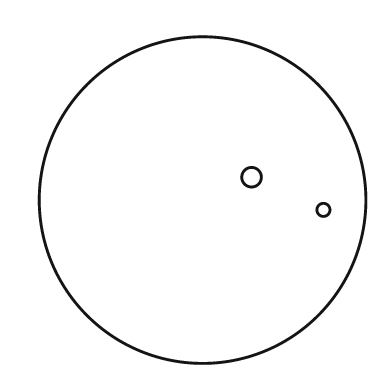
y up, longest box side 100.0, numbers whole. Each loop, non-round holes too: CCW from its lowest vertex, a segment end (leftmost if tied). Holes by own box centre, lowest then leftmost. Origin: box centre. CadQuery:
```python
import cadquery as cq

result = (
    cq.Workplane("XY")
    .moveTo(0.0, 0.0)
    .circle(50.0)
    .moveTo(37.0, -3.0)
    .circle(2.0)
    .moveTo(15.0, 7.0)
    .circle(3.0)
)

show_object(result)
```